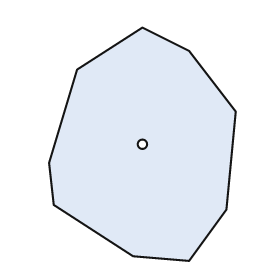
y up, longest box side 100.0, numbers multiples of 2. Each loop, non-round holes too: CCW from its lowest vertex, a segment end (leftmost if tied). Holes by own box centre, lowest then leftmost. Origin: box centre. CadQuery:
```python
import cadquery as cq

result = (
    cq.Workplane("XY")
    .moveTo(20.0, -50.0)
    .lineTo(36.0, -28.0)
    .lineTo(40.0, 14.0)
    .lineTo(20.0, 40.0)
    .lineTo(0.0, 50.0)
    .lineTo(-28.0, 32.0)
    .lineTo(-40.0, -8.0)
    .lineTo(-38.0, -26.0)
    .lineTo(-4.0, -48.0)
    .close()
    .moveTo(0.0, 0.0)
    .circle(2.0)
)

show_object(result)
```